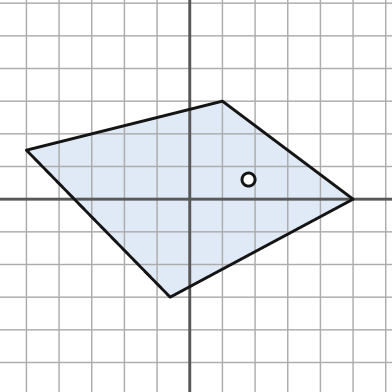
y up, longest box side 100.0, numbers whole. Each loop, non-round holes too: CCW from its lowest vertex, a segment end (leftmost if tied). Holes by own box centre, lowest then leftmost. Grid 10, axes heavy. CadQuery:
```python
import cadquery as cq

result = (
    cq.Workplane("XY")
    .moveTo(-6.0, -30.0)
    .lineTo(50.0, 0.0)
    .lineTo(10.0, 30.0)
    .lineTo(-50.0, 15.0)
    .close()
    .moveTo(18.0, 6.0)
    .circle(2.0)
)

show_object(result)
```